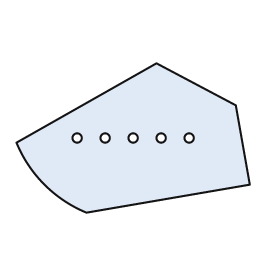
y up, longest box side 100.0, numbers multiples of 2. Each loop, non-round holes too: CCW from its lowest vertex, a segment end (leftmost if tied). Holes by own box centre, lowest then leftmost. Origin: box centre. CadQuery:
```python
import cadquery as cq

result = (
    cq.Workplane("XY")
    .moveTo(-20.0, -32.0)
    .lineTo(50.0, -20.0)
    .lineTo(44.0, 14.0)
    .lineTo(10.0, 32.0)
    .lineTo(-50.0, -2.0)
    .threePointArc((-38.0, -20.0), (-20.0, -32.0))
    .close()
    .moveTo(-24.0, 0.0)
    .circle(2.0)
    .moveTo(-12.0, 0.0)
    .circle(2.0)
    .moveTo(0.0, 0.0)
    .circle(2.0)
    .moveTo(12.0, 0.0)
    .circle(2.0)
    .moveTo(24.0, 0.0)
    .circle(2.0)
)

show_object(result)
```